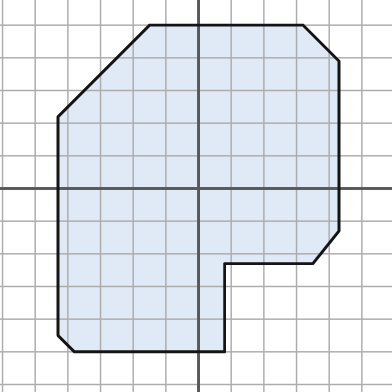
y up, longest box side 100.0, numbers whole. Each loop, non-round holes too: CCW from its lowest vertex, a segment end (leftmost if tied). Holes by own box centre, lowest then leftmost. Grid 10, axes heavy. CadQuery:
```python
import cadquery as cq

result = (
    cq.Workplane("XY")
    .moveTo(-38.0, -50.0)
    .lineTo(8.0, -50.0)
    .lineTo(8.0, -23.0)
    .lineTo(35.0, -23.0)
    .lineTo(43.0, -13.0)
    .lineTo(43.0, 39.0)
    .lineTo(32.0, 50.0)
    .lineTo(-15.0, 50.0)
    .lineTo(-43.0, 22.0)
    .lineTo(-43.0, -45.0)
    .close()
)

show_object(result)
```